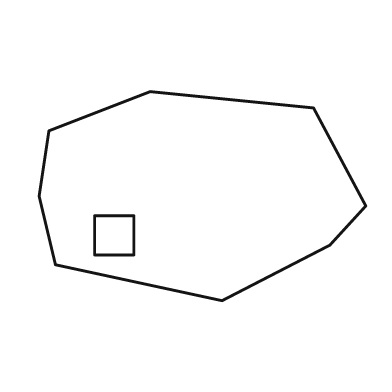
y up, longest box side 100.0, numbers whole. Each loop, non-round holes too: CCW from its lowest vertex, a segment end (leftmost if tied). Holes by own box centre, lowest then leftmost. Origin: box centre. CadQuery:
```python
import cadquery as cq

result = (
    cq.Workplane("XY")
    .moveTo(6.0, -32.0)
    .lineTo(39.0, -15.0)
    .lineTo(50.0, -3.0)
    .lineTo(34.0, 27.0)
    .lineTo(-16.0, 32.0)
    .lineTo(-47.0, 20.0)
    .lineTo(-50.0, 0.0)
    .lineTo(-45.0, -21.0)
    .close()
    .moveTo(-33.0, -18.0)
    .lineTo(-21.0, -18.0)
    .lineTo(-21.0, -6.0)
    .lineTo(-33.0, -6.0)
    .close()
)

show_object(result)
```